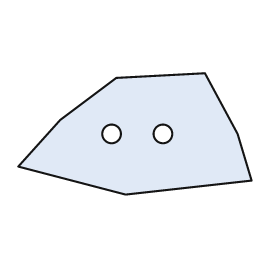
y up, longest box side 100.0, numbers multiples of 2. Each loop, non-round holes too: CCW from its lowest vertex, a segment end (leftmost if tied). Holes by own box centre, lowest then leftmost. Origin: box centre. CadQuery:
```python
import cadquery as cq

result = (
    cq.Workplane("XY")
    .moveTo(-4.0, -26.0)
    .lineTo(50.0, -20.0)
    .lineTo(44.0, 0.0)
    .lineTo(30.0, 26.0)
    .lineTo(-8.0, 24.0)
    .lineTo(-32.0, 6.0)
    .lineTo(-50.0, -14.0)
    .close()
    .moveTo(-10.0, 0.0)
    .circle(4.0)
    .moveTo(12.0, 0.0)
    .circle(4.0)
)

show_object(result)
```